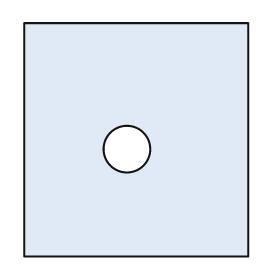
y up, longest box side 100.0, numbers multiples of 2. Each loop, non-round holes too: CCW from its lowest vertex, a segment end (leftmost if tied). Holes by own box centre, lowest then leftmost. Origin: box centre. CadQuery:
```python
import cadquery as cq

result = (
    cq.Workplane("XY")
    .moveTo(-48.0, -50.0)
    .lineTo(48.0, -50.0)
    .lineTo(48.0, 50.0)
    .lineTo(-48.0, 50.0)
    .close()
    .moveTo(-4.0, -4.0)
    .circle(10.0)
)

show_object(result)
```